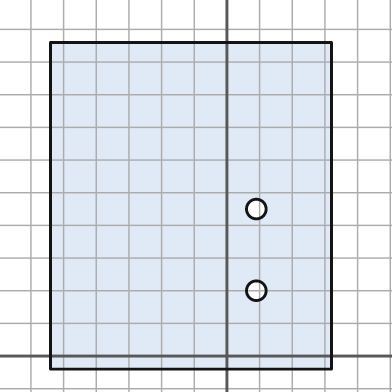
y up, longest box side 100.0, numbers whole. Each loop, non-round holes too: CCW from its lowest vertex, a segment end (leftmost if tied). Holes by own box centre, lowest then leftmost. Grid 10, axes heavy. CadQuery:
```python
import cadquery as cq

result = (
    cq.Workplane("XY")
    .moveTo(-54.0, -4.0)
    .lineTo(32.0, -4.0)
    .lineTo(32.0, 96.0)
    .lineTo(-54.0, 96.0)
    .close()
    .moveTo(9.0, 20.0)
    .circle(3.0)
    .moveTo(9.0, 45.0)
    .circle(3.0)
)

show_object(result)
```